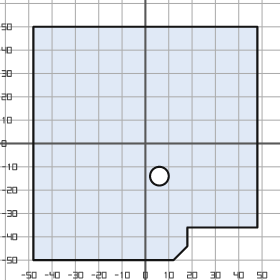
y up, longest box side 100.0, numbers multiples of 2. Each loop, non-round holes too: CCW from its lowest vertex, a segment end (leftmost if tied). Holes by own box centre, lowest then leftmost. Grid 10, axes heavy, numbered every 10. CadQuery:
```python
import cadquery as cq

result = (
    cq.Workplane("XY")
    .moveTo(-48.0, -50.0)
    .lineTo(12.0, -50.0)
    .lineTo(18.0, -44.0)
    .lineTo(18.0, -36.0)
    .lineTo(48.0, -36.0)
    .lineTo(48.0, 50.0)
    .lineTo(-48.0, 50.0)
    .close()
    .moveTo(6.0, -14.0)
    .circle(4.0)
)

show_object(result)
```